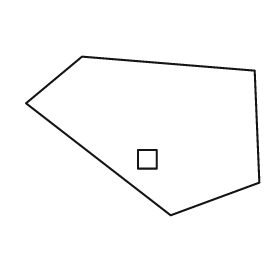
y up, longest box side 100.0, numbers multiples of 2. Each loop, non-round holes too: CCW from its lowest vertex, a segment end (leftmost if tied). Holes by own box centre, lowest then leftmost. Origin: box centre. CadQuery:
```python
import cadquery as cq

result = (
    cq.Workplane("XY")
    .moveTo(12.0, -34.0)
    .lineTo(50.0, -20.0)
    .lineTo(48.0, 28.0)
    .lineTo(-26.0, 34.0)
    .lineTo(-50.0, 14.0)
    .close()
    .moveTo(-2.0, -14.0)
    .lineTo(6.0, -14.0)
    .lineTo(6.0, -6.0)
    .lineTo(-2.0, -6.0)
    .close()
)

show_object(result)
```